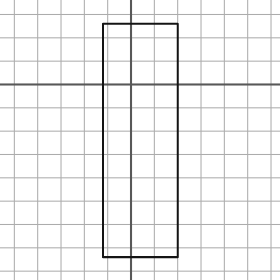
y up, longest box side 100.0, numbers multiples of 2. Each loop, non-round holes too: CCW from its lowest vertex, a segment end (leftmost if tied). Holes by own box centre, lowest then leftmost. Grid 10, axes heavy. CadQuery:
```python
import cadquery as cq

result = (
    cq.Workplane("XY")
    .moveTo(-12.0, -74.0)
    .lineTo(20.0, -74.0)
    .lineTo(20.0, 26.0)
    .lineTo(-12.0, 26.0)
    .close()
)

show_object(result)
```